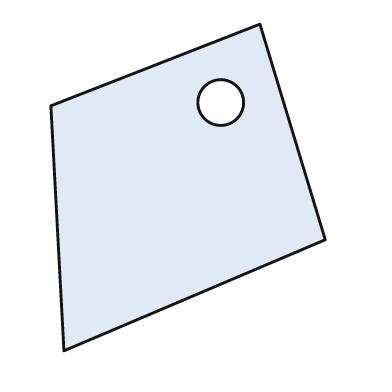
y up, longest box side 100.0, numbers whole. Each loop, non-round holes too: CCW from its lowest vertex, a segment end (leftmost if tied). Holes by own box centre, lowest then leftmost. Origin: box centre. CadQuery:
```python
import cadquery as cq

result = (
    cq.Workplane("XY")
    .moveTo(-38.0, -50.0)
    .lineTo(42.0, -16.0)
    .lineTo(22.0, 50.0)
    .lineTo(-42.0, 25.0)
    .close()
    .moveTo(10.0, 26.0)
    .circle(7.0)
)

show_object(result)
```